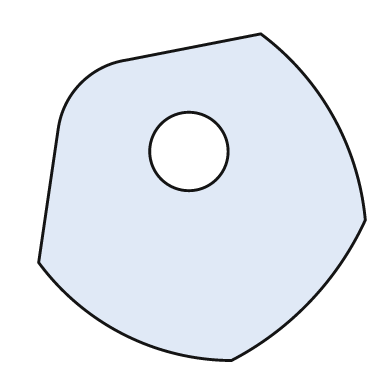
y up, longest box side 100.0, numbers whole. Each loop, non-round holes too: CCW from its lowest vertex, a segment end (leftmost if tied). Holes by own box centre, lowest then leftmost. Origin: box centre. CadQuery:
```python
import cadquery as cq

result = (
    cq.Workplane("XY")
    .moveTo(9.0, -50.0)
    .threePointArc((33.0, -32.0), (50.0, -7.0))
    .threePointArc((40.0, 25.0), (18.0, 50.0))
    .lineTo(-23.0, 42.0)
    .threePointArc((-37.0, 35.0), (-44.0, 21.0))
    .lineTo(-50.0, -20.0)
    .threePointArc((-24.0, -42.0), (9.0, -50.0))
    .close()
    .moveTo(-4.0, 14.0)
    .circle(12.0)
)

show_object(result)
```